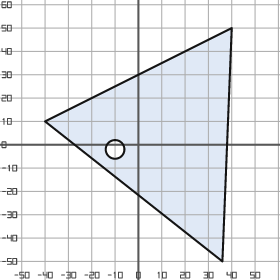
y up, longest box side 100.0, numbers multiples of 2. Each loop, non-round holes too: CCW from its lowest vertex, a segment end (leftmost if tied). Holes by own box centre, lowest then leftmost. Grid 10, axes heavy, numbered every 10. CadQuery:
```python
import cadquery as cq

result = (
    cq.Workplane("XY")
    .moveTo(36.0, -50.0)
    .lineTo(40.0, 50.0)
    .lineTo(-40.0, 10.0)
    .close()
    .moveTo(-10.0, -2.0)
    .circle(4.0)
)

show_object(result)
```